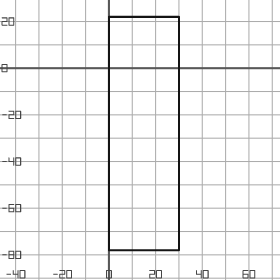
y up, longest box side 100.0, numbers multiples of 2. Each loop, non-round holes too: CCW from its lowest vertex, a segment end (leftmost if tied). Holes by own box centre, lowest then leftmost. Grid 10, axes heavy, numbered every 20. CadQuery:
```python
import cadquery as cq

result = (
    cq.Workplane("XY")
    .moveTo(0.0, -78.0)
    .lineTo(30.0, -78.0)
    .lineTo(30.0, 22.0)
    .lineTo(0.0, 22.0)
    .close()
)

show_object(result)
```